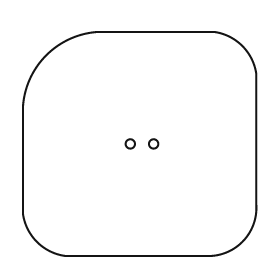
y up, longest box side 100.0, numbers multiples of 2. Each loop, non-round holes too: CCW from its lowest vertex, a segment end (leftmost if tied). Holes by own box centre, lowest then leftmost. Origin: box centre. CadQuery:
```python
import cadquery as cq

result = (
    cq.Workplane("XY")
    .moveTo(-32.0, -48.0)
    .lineTo(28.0, -48.0)
    .threePointArc((44.0, -42.0), (50.0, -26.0))
    .lineTo(50.0, 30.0)
    .threePointArc((44.0, 42.0), (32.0, 48.0))
    .lineTo(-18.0, 48.0)
    .threePointArc((-40.0, 38.0), (-50.0, 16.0))
    .lineTo(-50.0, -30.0)
    .threePointArc((-44.0, -42.0), (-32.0, -48.0))
    .close()
    .moveTo(-4.0, 0.0)
    .circle(2.0)
    .moveTo(6.0, 0.0)
    .circle(2.0)
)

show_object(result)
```